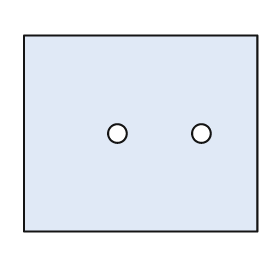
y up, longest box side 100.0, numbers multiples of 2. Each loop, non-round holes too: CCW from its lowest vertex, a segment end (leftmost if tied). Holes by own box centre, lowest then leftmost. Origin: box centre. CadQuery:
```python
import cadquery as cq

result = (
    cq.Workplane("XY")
    .moveTo(-50.0, -42.0)
    .lineTo(50.0, -42.0)
    .lineTo(50.0, 42.0)
    .lineTo(-50.0, 42.0)
    .close()
    .moveTo(-10.0, 0.0)
    .circle(4.0)
    .moveTo(26.0, 0.0)
    .circle(4.0)
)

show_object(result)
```